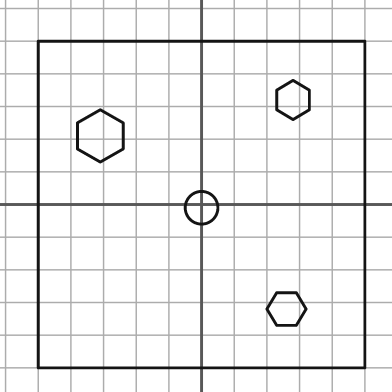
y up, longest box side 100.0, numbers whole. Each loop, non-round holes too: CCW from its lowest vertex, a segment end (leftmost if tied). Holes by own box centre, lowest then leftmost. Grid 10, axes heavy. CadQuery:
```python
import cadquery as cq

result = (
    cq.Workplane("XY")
    .moveTo(-50.0, -50.0)
    .lineTo(50.0, -50.0)
    .lineTo(50.0, 50.0)
    .lineTo(-50.0, 50.0)
    .close()
    .moveTo(23.0, -37.0)
    .lineTo(29.0, -37.0)
    .lineTo(32.0, -32.0)
    .lineTo(29.0, -27.0)
    .lineTo(23.0, -27.0)
    .lineTo(20.0, -32.0)
    .close()
    .moveTo(0.0, -1.0)
    .circle(5.0)
    .moveTo(-31.0, 13.0)
    .lineTo(-24.0, 17.0)
    .lineTo(-24.0, 25.0)
    .lineTo(-31.0, 29.0)
    .lineTo(-38.0, 25.0)
    .lineTo(-38.0, 17.0)
    .close()
    .moveTo(28.0, 26.0)
    .lineTo(33.0, 29.0)
    .lineTo(33.0, 35.0)
    .lineTo(28.0, 38.0)
    .lineTo(23.0, 35.0)
    .lineTo(23.0, 29.0)
    .close()
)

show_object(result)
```